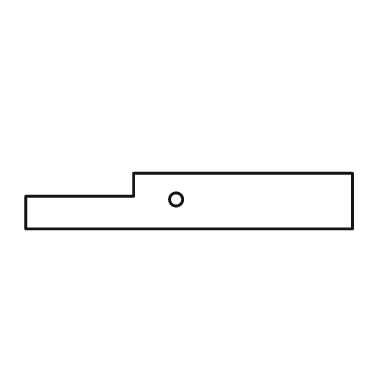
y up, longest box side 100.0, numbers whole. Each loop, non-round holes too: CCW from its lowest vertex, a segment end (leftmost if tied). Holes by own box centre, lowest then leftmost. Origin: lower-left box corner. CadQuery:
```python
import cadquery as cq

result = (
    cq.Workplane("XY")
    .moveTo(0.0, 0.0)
    .lineTo(100.0, 0.0)
    .lineTo(100.0, 17.0)
    .lineTo(33.0, 17.0)
    .lineTo(33.0, 10.0)
    .lineTo(0.0, 10.0)
    .close()
    .moveTo(46.0, 9.0)
    .circle(2.0)
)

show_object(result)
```